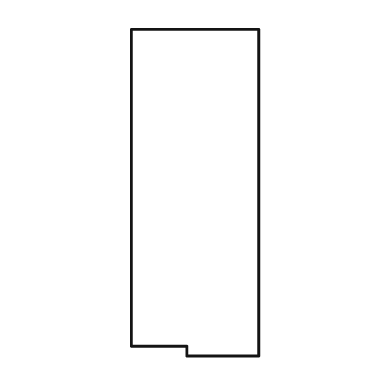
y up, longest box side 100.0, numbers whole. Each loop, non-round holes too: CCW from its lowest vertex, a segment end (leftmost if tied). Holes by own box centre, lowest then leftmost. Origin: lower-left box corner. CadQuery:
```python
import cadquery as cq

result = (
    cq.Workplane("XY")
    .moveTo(17.0, 0.0)
    .lineTo(39.0, 0.0)
    .lineTo(39.0, 100.0)
    .lineTo(0.0, 100.0)
    .lineTo(0.0, 3.0)
    .lineTo(17.0, 3.0)
    .close()
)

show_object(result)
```